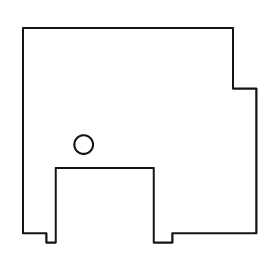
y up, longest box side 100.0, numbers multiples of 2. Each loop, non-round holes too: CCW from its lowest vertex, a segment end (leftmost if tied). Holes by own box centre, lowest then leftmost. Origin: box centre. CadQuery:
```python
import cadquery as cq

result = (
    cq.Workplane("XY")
    .moveTo(-40.0, -46.0)
    .lineTo(-36.0, -46.0)
    .lineTo(-36.0, -14.0)
    .lineTo(6.0, -14.0)
    .lineTo(6.0, -46.0)
    .lineTo(14.0, -46.0)
    .lineTo(14.0, -42.0)
    .lineTo(50.0, -42.0)
    .lineTo(50.0, 20.0)
    .lineTo(40.0, 20.0)
    .lineTo(40.0, 46.0)
    .lineTo(-50.0, 46.0)
    .lineTo(-50.0, -42.0)
    .lineTo(-40.0, -42.0)
    .close()
    .moveTo(-24.0, -4.0)
    .circle(4.0)
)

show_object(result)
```